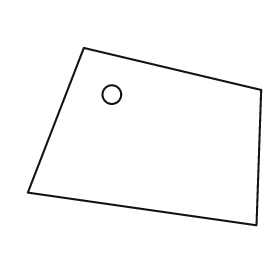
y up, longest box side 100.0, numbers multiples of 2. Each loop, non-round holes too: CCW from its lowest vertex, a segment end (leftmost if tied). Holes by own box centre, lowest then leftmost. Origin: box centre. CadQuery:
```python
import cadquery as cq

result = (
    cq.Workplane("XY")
    .moveTo(48.0, -38.0)
    .lineTo(50.0, 20.0)
    .lineTo(-26.0, 38.0)
    .lineTo(-50.0, -24.0)
    .close()
    .moveTo(-14.0, 18.0)
    .circle(4.0)
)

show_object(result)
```